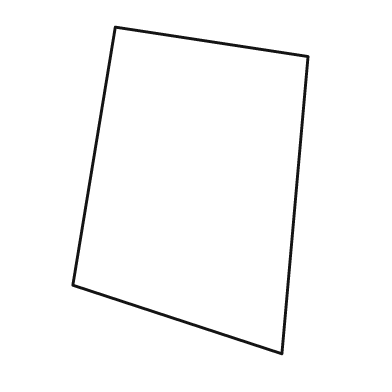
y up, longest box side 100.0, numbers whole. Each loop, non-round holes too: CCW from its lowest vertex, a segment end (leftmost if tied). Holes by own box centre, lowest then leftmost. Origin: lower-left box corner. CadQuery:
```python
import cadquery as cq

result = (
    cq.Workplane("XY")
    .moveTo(64.0, 0.0)
    .lineTo(72.0, 91.0)
    .lineTo(13.0, 100.0)
    .lineTo(0.0, 21.0)
    .close()
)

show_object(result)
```